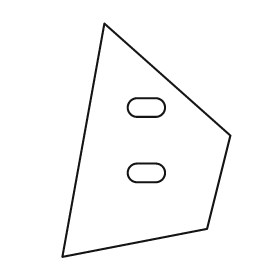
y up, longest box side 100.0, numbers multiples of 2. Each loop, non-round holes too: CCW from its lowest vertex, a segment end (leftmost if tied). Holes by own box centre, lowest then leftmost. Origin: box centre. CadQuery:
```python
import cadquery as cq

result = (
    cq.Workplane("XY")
    .moveTo(-36.0, -50.0)
    .lineTo(26.0, -38.0)
    .lineTo(36.0, 2.0)
    .lineTo(-18.0, 50.0)
    .close()
    .moveTo(-4.0, -18.0)
    .lineTo(4.0, -18.0)
    .threePointArc((8.0, -14.0), (4.0, -10.0))
    .lineTo(-4.0, -10.0)
    .threePointArc((-8.0, -14.0), (-4.0, -18.0))
    .close()
    .moveTo(-4.0, 10.0)
    .lineTo(4.0, 10.0)
    .threePointArc((8.0, 14.0), (4.0, 18.0))
    .lineTo(-4.0, 18.0)
    .threePointArc((-8.0, 14.0), (-4.0, 10.0))
    .close()
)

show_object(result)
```